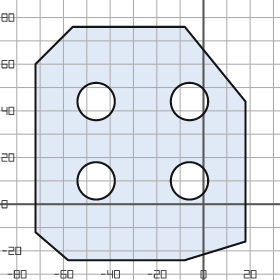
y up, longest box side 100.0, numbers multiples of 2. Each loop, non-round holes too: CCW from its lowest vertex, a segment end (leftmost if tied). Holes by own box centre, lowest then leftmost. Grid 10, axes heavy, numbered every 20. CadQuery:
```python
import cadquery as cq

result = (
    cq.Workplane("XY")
    .moveTo(-58.0, -24.0)
    .lineTo(-8.0, -24.0)
    .lineTo(18.0, -16.0)
    .lineTo(18.0, 44.0)
    .lineTo(-8.0, 76.0)
    .lineTo(-56.0, 76.0)
    .lineTo(-72.0, 60.0)
    .lineTo(-72.0, -12.0)
    .close()
    .moveTo(-46.0, 10.0)
    .circle(8.0)
    .moveTo(-6.0, 10.0)
    .circle(8.0)
    .moveTo(-46.0, 44.0)
    .circle(8.0)
    .moveTo(-6.0, 44.0)
    .circle(8.0)
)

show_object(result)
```